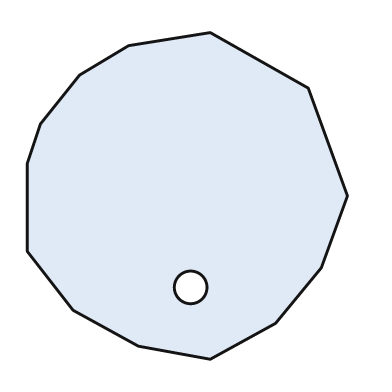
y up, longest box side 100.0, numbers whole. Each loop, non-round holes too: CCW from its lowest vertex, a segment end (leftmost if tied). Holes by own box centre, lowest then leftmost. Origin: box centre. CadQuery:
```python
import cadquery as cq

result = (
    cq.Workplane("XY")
    .moveTo(7.0, -50.0)
    .lineTo(27.0, -39.0)
    .lineTo(41.0, -22.0)
    .lineTo(49.0, 0.0)
    .lineTo(37.0, 33.0)
    .lineTo(7.0, 50.0)
    .lineTo(-18.0, 46.0)
    .lineTo(-33.0, 37.0)
    .lineTo(-45.0, 22.0)
    .lineTo(-49.0, 10.0)
    .lineTo(-49.0, -17.0)
    .lineTo(-35.0, -35.0)
    .lineTo(-15.0, -46.0)
    .close()
    .moveTo(1.0, -28.0)
    .circle(5.0)
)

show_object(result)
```